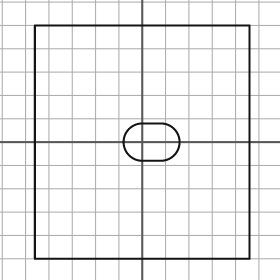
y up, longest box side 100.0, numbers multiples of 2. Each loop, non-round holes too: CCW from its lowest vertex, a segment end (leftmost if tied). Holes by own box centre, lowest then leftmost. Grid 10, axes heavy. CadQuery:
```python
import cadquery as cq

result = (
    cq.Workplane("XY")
    .moveTo(-46.0, -50.0)
    .lineTo(46.0, -50.0)
    .lineTo(46.0, 50.0)
    .lineTo(-46.0, 50.0)
    .close()
    .moveTo(0.0, -8.0)
    .lineTo(8.0, -8.0)
    .threePointArc((16.0, 0.0), (8.0, 8.0))
    .lineTo(0.0, 8.0)
    .threePointArc((-8.0, 0.0), (0.0, -8.0))
    .close()
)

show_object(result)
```